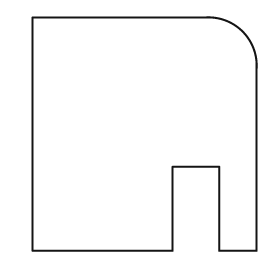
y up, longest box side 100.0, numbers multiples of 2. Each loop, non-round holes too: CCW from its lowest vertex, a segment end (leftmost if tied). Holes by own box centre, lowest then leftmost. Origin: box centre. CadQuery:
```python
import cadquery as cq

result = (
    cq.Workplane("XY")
    .moveTo(-48.0, -50.0)
    .lineTo(12.0, -50.0)
    .lineTo(12.0, -14.0)
    .lineTo(32.0, -14.0)
    .lineTo(32.0, -50.0)
    .lineTo(48.0, -50.0)
    .lineTo(48.0, 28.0)
    .threePointArc((42.0, 44.0), (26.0, 50.0))
    .lineTo(-48.0, 50.0)
    .close()
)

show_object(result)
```